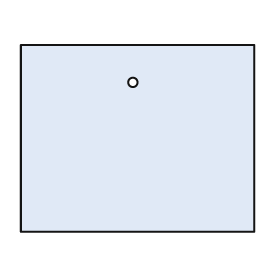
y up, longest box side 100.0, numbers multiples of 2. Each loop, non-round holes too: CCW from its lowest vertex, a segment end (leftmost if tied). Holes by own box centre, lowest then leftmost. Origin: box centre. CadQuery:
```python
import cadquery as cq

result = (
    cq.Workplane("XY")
    .moveTo(-50.0, -40.0)
    .lineTo(50.0, -40.0)
    .lineTo(50.0, 40.0)
    .lineTo(-50.0, 40.0)
    .close()
    .moveTo(-2.0, 24.0)
    .circle(2.0)
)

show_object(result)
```